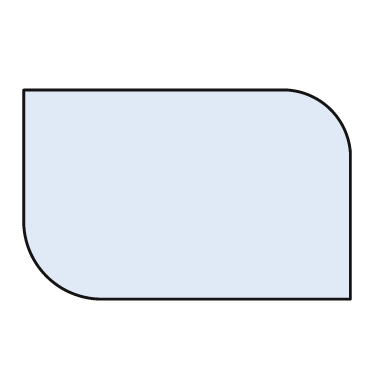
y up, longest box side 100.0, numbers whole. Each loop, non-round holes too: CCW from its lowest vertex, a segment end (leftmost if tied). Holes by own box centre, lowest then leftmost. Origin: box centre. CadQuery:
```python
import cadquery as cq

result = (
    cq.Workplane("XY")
    .moveTo(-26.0, -32.0)
    .lineTo(50.0, -32.0)
    .lineTo(50.0, 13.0)
    .threePointArc((44.0, 26.0), (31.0, 32.0))
    .lineTo(-50.0, 32.0)
    .lineTo(-50.0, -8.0)
    .threePointArc((-43.0, -25.0), (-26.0, -32.0))
    .close()
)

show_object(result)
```